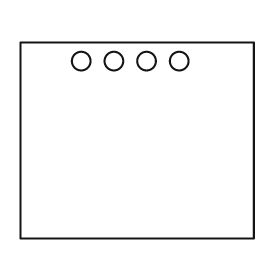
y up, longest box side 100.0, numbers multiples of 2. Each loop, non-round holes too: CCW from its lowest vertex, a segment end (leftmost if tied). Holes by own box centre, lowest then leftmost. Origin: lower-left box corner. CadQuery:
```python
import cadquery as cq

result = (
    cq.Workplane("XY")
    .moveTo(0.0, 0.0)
    .lineTo(100.0, 0.0)
    .lineTo(100.0, 84.0)
    .lineTo(0.0, 84.0)
    .close()
    .moveTo(26.0, 76.0)
    .circle(4.0)
    .moveTo(40.0, 76.0)
    .circle(4.0)
    .moveTo(54.0, 76.0)
    .circle(4.0)
    .moveTo(68.0, 76.0)
    .circle(4.0)
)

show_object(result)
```